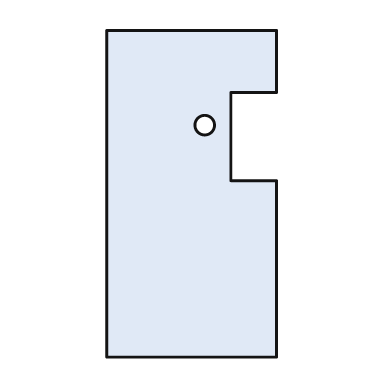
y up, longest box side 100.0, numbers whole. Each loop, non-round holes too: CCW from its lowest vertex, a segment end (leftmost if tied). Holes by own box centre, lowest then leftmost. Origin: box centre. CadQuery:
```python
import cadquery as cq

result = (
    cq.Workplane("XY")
    .moveTo(-26.0, -50.0)
    .lineTo(26.0, -50.0)
    .lineTo(26.0, 4.0)
    .lineTo(12.0, 4.0)
    .lineTo(12.0, 31.0)
    .lineTo(26.0, 31.0)
    .lineTo(26.0, 50.0)
    .lineTo(-26.0, 50.0)
    .close()
    .moveTo(4.0, 21.0)
    .circle(3.0)
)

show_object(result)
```